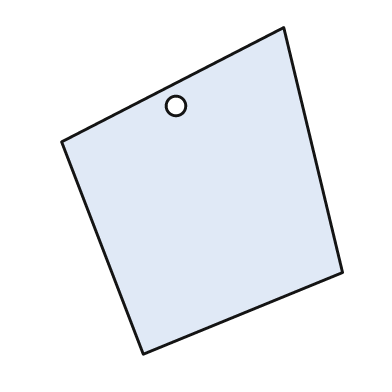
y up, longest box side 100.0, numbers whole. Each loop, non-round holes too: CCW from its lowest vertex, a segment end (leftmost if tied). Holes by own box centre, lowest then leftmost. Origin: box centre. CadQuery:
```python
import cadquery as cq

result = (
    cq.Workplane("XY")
    .moveTo(-18.0, -50.0)
    .lineTo(43.0, -25.0)
    .lineTo(25.0, 50.0)
    .lineTo(-43.0, 15.0)
    .close()
    .moveTo(-8.0, 26.0)
    .circle(3.0)
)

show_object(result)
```